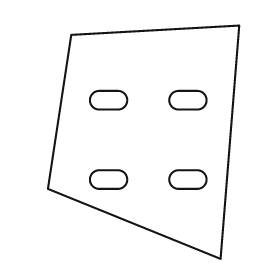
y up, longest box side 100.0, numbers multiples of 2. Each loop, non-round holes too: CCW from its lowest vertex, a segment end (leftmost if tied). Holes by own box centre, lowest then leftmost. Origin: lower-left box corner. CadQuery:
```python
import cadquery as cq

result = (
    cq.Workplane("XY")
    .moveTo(74.0, 0.0)
    .lineTo(82.0, 100.0)
    .lineTo(10.0, 96.0)
    .lineTo(0.0, 30.0)
    .close()
    .moveTo(22.0, 30.0)
    .lineTo(30.0, 30.0)
    .threePointArc((34.0, 34.0), (30.0, 38.0))
    .lineTo(22.0, 38.0)
    .threePointArc((18.0, 34.0), (22.0, 30.0))
    .close()
    .moveTo(56.0, 30.0)
    .lineTo(64.0, 30.0)
    .threePointArc((68.0, 34.0), (64.0, 38.0))
    .lineTo(56.0, 38.0)
    .threePointArc((52.0, 34.0), (56.0, 30.0))
    .close()
    .moveTo(22.0, 64.0)
    .lineTo(30.0, 64.0)
    .threePointArc((34.0, 68.0), (30.0, 72.0))
    .lineTo(22.0, 72.0)
    .threePointArc((18.0, 68.0), (22.0, 64.0))
    .close()
    .moveTo(56.0, 64.0)
    .lineTo(64.0, 64.0)
    .threePointArc((68.0, 68.0), (64.0, 72.0))
    .lineTo(56.0, 72.0)
    .threePointArc((52.0, 68.0), (56.0, 64.0))
    .close()
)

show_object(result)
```